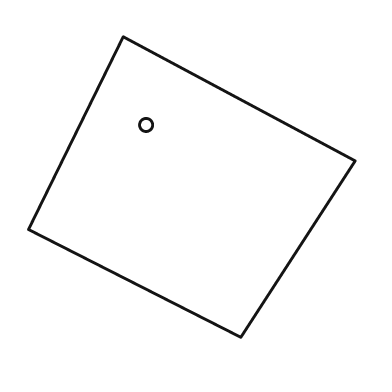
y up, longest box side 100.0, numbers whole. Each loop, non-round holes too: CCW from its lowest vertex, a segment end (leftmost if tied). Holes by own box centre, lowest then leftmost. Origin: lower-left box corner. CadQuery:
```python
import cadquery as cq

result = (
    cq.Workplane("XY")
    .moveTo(65.0, 0.0)
    .lineTo(100.0, 54.0)
    .lineTo(29.0, 92.0)
    .lineTo(0.0, 33.0)
    .close()
    .moveTo(36.0, 65.0)
    .circle(2.0)
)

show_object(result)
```